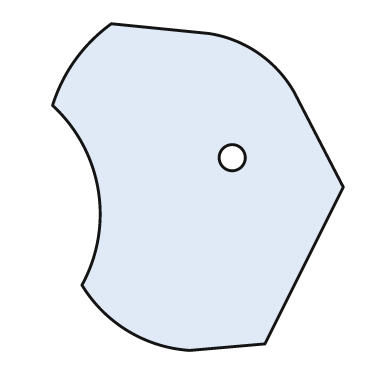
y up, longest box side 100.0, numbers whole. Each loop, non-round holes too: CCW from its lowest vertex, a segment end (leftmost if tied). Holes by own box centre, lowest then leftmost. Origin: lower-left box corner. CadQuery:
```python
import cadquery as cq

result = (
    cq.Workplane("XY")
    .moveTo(42.0, 0.0)
    .lineTo(65.0, 2.0)
    .lineTo(89.0, 50.0)
    .lineTo(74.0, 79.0)
    .threePointArc((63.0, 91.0), (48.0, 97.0))
    .lineTo(18.0, 100.0)
    .threePointArc((7.0, 89.0), (0.0, 75.0))
    .threePointArc((14.0, 49.0), (9.0, 20.0))
    .threePointArc((23.0, 6.0), (42.0, 0.0))
    .close()
    .moveTo(55.0, 59.0)
    .circle(4.0)
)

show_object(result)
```